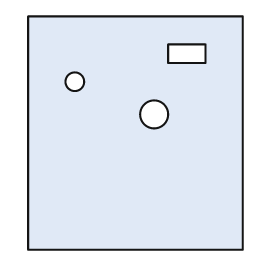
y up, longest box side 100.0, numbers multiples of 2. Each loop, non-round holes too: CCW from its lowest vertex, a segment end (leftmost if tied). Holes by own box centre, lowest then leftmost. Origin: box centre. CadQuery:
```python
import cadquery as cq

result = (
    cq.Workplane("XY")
    .moveTo(-46.0, -50.0)
    .lineTo(46.0, -50.0)
    .lineTo(46.0, 50.0)
    .lineTo(-46.0, 50.0)
    .close()
    .moveTo(8.0, 8.0)
    .circle(6.0)
    .moveTo(-26.0, 22.0)
    .circle(4.0)
    .moveTo(14.0, 30.0)
    .lineTo(30.0, 30.0)
    .lineTo(30.0, 38.0)
    .lineTo(14.0, 38.0)
    .close()
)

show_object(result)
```